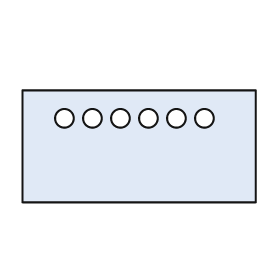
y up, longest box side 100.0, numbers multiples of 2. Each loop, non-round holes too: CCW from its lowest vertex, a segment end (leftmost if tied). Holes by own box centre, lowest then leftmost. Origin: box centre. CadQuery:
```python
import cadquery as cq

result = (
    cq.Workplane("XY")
    .moveTo(-50.0, -24.0)
    .lineTo(50.0, -24.0)
    .lineTo(50.0, 24.0)
    .lineTo(-50.0, 24.0)
    .close()
    .moveTo(-32.0, 12.0)
    .circle(4.0)
    .moveTo(-20.0, 12.0)
    .circle(4.0)
    .moveTo(-8.0, 12.0)
    .circle(4.0)
    .moveTo(4.0, 12.0)
    .circle(4.0)
    .moveTo(16.0, 12.0)
    .circle(4.0)
    .moveTo(28.0, 12.0)
    .circle(4.0)
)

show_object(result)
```